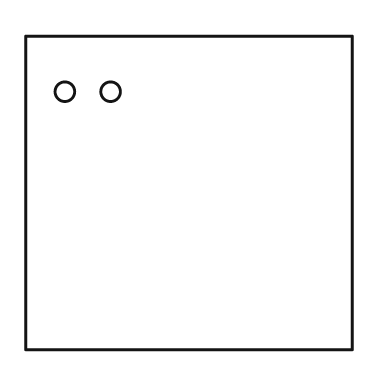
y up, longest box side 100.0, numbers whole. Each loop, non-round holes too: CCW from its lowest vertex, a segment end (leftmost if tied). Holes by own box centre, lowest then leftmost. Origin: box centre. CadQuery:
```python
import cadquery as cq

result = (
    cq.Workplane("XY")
    .moveTo(-50.0, -48.0)
    .lineTo(50.0, -48.0)
    .lineTo(50.0, 48.0)
    .lineTo(-50.0, 48.0)
    .close()
    .moveTo(-38.0, 31.0)
    .circle(3.0)
    .moveTo(-24.0, 31.0)
    .circle(3.0)
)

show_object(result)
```